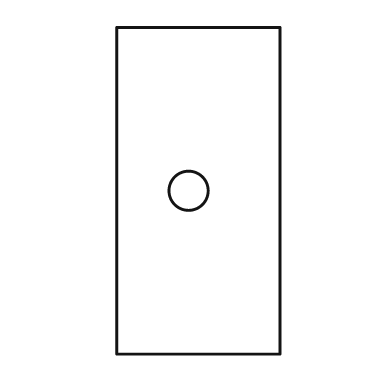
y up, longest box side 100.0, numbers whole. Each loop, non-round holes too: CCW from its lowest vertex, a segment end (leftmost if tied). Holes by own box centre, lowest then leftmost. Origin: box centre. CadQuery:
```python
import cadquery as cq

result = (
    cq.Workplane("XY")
    .moveTo(-25.0, -50.0)
    .lineTo(25.0, -50.0)
    .lineTo(25.0, 50.0)
    .lineTo(-25.0, 50.0)
    .close()
    .moveTo(-3.0, 0.0)
    .circle(6.0)
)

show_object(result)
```